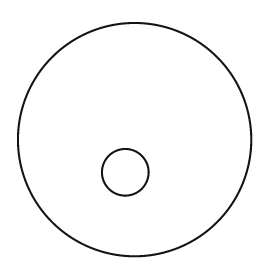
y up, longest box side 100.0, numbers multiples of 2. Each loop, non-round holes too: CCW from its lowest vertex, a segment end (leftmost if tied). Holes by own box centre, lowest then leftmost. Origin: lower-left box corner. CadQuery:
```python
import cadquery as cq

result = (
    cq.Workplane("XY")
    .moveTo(50.0, 50.0)
    .circle(50.0)
    .moveTo(46.0, 36.0)
    .circle(10.0)
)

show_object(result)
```